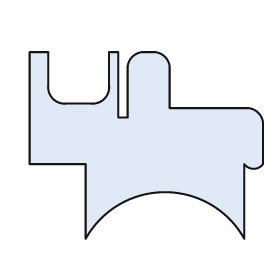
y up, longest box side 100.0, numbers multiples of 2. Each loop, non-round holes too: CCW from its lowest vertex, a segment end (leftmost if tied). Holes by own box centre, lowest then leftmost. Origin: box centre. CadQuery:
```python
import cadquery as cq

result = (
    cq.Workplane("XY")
    .moveTo(-26.0, -40.0)
    .threePointArc((8.0, -20.0), (42.0, -40.0))
    .lineTo(42.0, -8.0)
    .threePointArc((46.0, -10.0), (50.0, -8.0))
    .lineTo(50.0, 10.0)
    .threePointArc((48.0, 14.0), (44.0, 16.0))
    .lineTo(10.0, 16.0)
    .lineTo(10.0, 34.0)
    .threePointArc((8.0, 38.0), (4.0, 40.0))
    .lineTo(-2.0, 40.0)
    .threePointArc((-6.0, 38.0), (-8.0, 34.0))
    .lineTo(-8.0, 12.0)
    .lineTo(-12.0, 12.0)
    .lineTo(-12.0, 40.0)
    .lineTo(-16.0, 40.0)
    .lineTo(-16.0, 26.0)
    .threePointArc((-18.0, 20.0), (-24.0, 18.0))
    .lineTo(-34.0, 18.0)
    .threePointArc((-40.0, 20.0), (-42.0, 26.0))
    .lineTo(-42.0, 40.0)
    .lineTo(-50.0, 40.0)
    .lineTo(-50.0, -8.0)
    .lineTo(-26.0, -8.0)
    .close()
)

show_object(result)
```